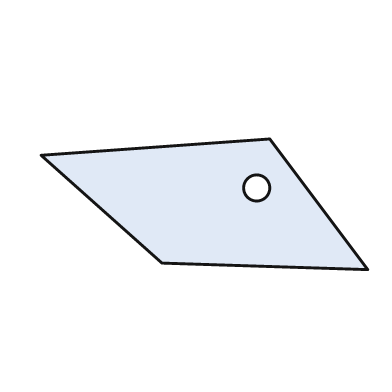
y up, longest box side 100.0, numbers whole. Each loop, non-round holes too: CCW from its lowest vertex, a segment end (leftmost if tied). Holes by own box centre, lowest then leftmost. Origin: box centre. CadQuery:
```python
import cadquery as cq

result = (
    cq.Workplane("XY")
    .moveTo(50.0, -20.0)
    .lineTo(20.0, 20.0)
    .lineTo(-50.0, 15.0)
    .lineTo(-13.0, -18.0)
    .close()
    .moveTo(16.0, 5.0)
    .circle(4.0)
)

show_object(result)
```